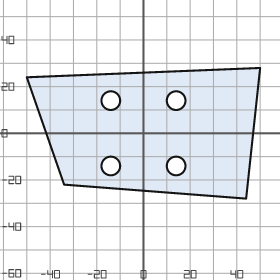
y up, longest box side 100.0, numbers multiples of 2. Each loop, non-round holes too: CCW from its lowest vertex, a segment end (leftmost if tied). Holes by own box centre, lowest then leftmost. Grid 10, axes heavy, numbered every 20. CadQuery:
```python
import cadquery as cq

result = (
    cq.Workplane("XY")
    .moveTo(44.0, -28.0)
    .lineTo(50.0, 28.0)
    .lineTo(-50.0, 24.0)
    .lineTo(-34.0, -22.0)
    .close()
    .moveTo(-14.0, -14.0)
    .circle(4.0)
    .moveTo(14.0, -14.0)
    .circle(4.0)
    .moveTo(-14.0, 14.0)
    .circle(4.0)
    .moveTo(14.0, 14.0)
    .circle(4.0)
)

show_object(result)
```